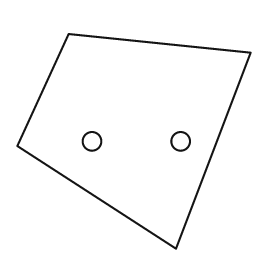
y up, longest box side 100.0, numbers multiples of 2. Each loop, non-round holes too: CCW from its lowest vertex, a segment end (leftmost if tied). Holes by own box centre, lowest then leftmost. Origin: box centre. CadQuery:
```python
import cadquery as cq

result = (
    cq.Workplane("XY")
    .moveTo(18.0, -46.0)
    .lineTo(50.0, 38.0)
    .lineTo(-28.0, 46.0)
    .lineTo(-50.0, -2.0)
    .close()
    .moveTo(-18.0, 0.0)
    .circle(4.0)
    .moveTo(20.0, 0.0)
    .circle(4.0)
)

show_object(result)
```